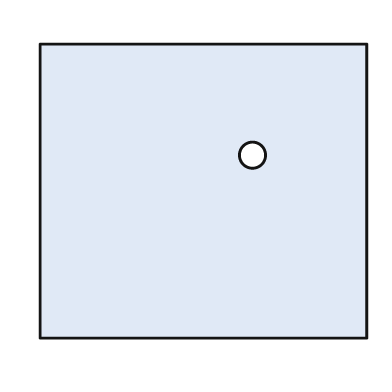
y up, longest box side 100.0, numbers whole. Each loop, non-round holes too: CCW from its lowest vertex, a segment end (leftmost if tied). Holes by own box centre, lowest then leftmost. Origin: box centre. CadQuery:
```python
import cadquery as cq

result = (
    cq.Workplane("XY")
    .moveTo(-50.0, -45.0)
    .lineTo(50.0, -45.0)
    .lineTo(50.0, 45.0)
    .lineTo(-50.0, 45.0)
    .close()
    .moveTo(15.0, 11.0)
    .circle(4.0)
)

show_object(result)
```